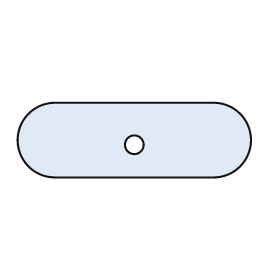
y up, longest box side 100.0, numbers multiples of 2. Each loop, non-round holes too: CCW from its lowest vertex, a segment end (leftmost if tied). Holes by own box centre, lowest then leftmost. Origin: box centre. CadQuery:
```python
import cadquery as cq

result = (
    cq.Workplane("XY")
    .moveTo(-34.0, -16.0)
    .lineTo(34.0, -16.0)
    .threePointArc((50.0, 0.0), (34.0, 16.0))
    .lineTo(-34.0, 16.0)
    .threePointArc((-50.0, 0.0), (-34.0, -16.0))
    .close()
    .moveTo(0.0, -2.0)
    .circle(4.0)
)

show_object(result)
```